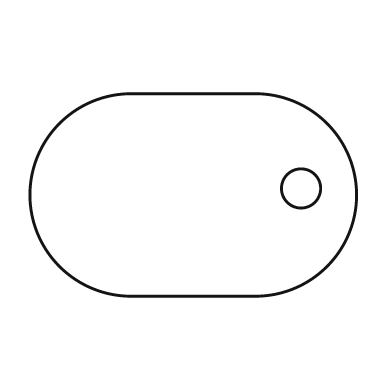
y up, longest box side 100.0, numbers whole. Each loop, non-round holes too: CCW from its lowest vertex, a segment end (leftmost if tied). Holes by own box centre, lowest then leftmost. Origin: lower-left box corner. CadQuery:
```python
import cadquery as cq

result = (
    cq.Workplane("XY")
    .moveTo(31.0, 0.0)
    .lineTo(69.0, 0.0)
    .threePointArc((100.0, 31.0), (69.0, 62.0))
    .lineTo(31.0, 62.0)
    .threePointArc((0.0, 31.0), (31.0, 0.0))
    .close()
    .moveTo(83.0, 33.0)
    .circle(6.0)
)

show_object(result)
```